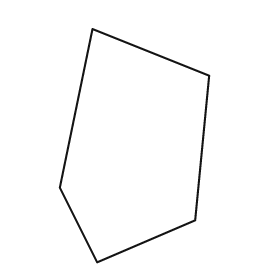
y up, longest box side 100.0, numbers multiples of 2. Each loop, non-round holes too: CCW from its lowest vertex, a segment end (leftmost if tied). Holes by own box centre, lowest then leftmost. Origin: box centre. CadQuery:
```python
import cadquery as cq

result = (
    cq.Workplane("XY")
    .moveTo(-16.0, -50.0)
    .lineTo(26.0, -32.0)
    .lineTo(32.0, 30.0)
    .lineTo(-18.0, 50.0)
    .lineTo(-32.0, -18.0)
    .close()
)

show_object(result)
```